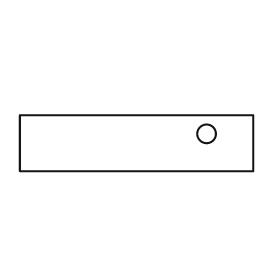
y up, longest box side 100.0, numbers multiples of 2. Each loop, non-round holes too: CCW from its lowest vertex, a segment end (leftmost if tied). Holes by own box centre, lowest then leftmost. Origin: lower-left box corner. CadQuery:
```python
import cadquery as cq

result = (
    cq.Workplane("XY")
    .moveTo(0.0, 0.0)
    .lineTo(100.0, 0.0)
    .lineTo(100.0, 24.0)
    .lineTo(0.0, 24.0)
    .close()
    .moveTo(80.0, 16.0)
    .circle(4.0)
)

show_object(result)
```